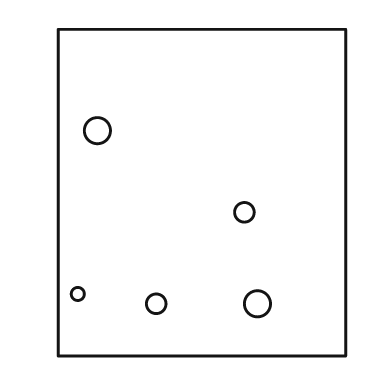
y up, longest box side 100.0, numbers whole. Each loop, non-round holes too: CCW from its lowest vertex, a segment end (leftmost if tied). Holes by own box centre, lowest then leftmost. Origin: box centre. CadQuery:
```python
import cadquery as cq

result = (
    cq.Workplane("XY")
    .moveTo(-44.0, -50.0)
    .lineTo(44.0, -50.0)
    .lineTo(44.0, 50.0)
    .lineTo(-44.0, 50.0)
    .close()
    .moveTo(-14.0, -34.0)
    .circle(3.0)
    .moveTo(17.0, -34.0)
    .circle(4.0)
    .moveTo(-38.0, -31.0)
    .circle(2.0)
    .moveTo(13.0, -6.0)
    .circle(3.0)
    .moveTo(-32.0, 19.0)
    .circle(4.0)
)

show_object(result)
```